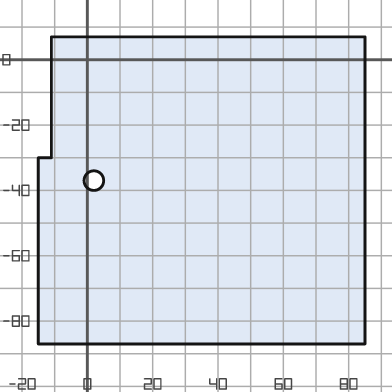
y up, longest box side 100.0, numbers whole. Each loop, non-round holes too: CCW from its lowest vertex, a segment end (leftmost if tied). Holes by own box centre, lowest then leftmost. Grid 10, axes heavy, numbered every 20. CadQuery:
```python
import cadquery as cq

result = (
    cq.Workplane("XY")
    .moveTo(-15.0, -87.0)
    .lineTo(85.0, -87.0)
    .lineTo(85.0, 7.0)
    .lineTo(-11.0, 7.0)
    .lineTo(-11.0, -30.0)
    .lineTo(-15.0, -30.0)
    .close()
    .moveTo(2.0, -37.0)
    .circle(3.0)
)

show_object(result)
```